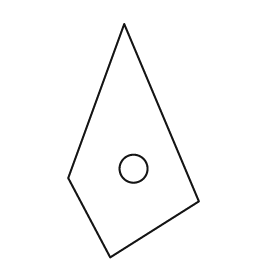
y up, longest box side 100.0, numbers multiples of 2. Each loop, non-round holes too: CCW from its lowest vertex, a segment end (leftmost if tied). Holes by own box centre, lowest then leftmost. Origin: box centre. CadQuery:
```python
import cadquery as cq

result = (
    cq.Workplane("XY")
    .moveTo(-10.0, -50.0)
    .lineTo(28.0, -26.0)
    .lineTo(-4.0, 50.0)
    .lineTo(-28.0, -16.0)
    .close()
    .moveTo(0.0, -12.0)
    .circle(6.0)
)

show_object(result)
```